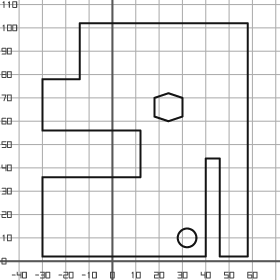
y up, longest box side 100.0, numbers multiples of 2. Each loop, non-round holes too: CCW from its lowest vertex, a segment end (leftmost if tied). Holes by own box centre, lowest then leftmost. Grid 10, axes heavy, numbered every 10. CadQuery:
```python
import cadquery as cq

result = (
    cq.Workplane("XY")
    .moveTo(-30.0, 2.0)
    .lineTo(40.0, 2.0)
    .lineTo(40.0, 44.0)
    .lineTo(46.0, 44.0)
    .lineTo(46.0, 2.0)
    .lineTo(58.0, 2.0)
    .lineTo(58.0, 102.0)
    .lineTo(-14.0, 102.0)
    .lineTo(-14.0, 78.0)
    .lineTo(-30.0, 78.0)
    .lineTo(-30.0, 56.0)
    .lineTo(12.0, 56.0)
    .lineTo(12.0, 36.0)
    .lineTo(-30.0, 36.0)
    .close()
    .moveTo(32.0, 10.0)
    .circle(4.0)
    .moveTo(24.0, 60.0)
    .lineTo(30.0, 62.0)
    .lineTo(30.0, 70.0)
    .lineTo(24.0, 72.0)
    .lineTo(18.0, 70.0)
    .lineTo(18.0, 62.0)
    .close()
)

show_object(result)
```